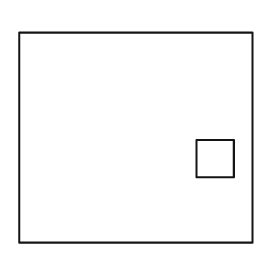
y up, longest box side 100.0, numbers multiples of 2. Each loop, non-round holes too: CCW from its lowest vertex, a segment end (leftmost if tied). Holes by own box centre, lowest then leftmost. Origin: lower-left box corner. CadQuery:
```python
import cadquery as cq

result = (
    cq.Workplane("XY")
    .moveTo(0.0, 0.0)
    .lineTo(100.0, 0.0)
    .lineTo(100.0, 90.0)
    .lineTo(0.0, 90.0)
    .close()
    .moveTo(76.0, 28.0)
    .lineTo(92.0, 28.0)
    .lineTo(92.0, 44.0)
    .lineTo(76.0, 44.0)
    .close()
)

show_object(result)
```